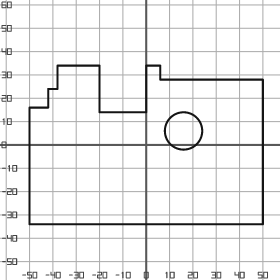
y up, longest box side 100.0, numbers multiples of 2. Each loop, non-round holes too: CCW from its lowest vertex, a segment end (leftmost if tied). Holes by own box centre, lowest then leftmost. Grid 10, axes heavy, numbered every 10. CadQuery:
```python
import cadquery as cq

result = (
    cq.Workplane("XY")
    .moveTo(-50.0, -34.0)
    .lineTo(50.0, -34.0)
    .lineTo(50.0, 28.0)
    .lineTo(6.0, 28.0)
    .lineTo(6.0, 34.0)
    .lineTo(0.0, 34.0)
    .lineTo(0.0, 14.0)
    .lineTo(-20.0, 14.0)
    .lineTo(-20.0, 34.0)
    .lineTo(-38.0, 34.0)
    .lineTo(-38.0, 24.0)
    .lineTo(-42.0, 24.0)
    .lineTo(-42.0, 16.0)
    .lineTo(-50.0, 16.0)
    .close()
    .moveTo(16.0, 6.0)
    .circle(8.0)
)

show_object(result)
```